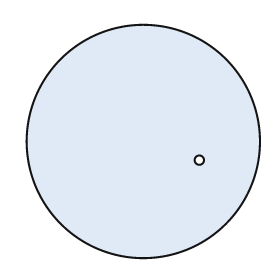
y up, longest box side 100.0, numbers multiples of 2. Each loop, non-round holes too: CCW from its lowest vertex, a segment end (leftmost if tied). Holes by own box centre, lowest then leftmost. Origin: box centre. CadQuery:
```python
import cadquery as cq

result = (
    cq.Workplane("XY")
    .moveTo(0.0, 0.0)
    .circle(50.0)
    .moveTo(24.0, -8.0)
    .circle(2.0)
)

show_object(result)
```